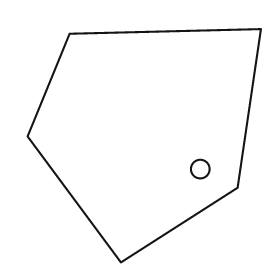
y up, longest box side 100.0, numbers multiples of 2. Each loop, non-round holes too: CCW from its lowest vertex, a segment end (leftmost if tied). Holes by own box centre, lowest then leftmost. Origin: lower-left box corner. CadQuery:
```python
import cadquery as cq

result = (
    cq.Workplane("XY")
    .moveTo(40.0, 0.0)
    .lineTo(90.0, 32.0)
    .lineTo(100.0, 100.0)
    .lineTo(18.0, 98.0)
    .lineTo(0.0, 54.0)
    .close()
    .moveTo(74.0, 40.0)
    .circle(4.0)
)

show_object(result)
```